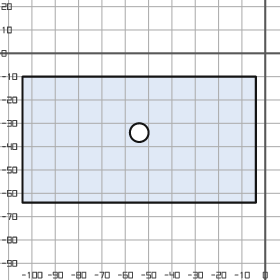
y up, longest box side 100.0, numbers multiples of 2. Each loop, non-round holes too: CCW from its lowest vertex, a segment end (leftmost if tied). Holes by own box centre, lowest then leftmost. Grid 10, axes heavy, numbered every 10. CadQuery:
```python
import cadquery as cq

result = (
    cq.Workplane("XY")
    .moveTo(-104.0, -64.0)
    .lineTo(-4.0, -64.0)
    .lineTo(-4.0, -10.0)
    .lineTo(-104.0, -10.0)
    .close()
    .moveTo(-54.0, -34.0)
    .circle(4.0)
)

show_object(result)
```